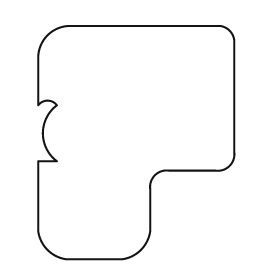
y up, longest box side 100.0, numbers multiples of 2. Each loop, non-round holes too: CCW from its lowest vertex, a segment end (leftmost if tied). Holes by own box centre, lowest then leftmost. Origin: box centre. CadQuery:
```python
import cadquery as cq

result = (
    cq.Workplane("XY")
    .moveTo(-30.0, -50.0)
    .lineTo(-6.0, -50.0)
    .threePointArc((2.0, -46.0), (6.0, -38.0))
    .lineTo(6.0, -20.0)
    .threePointArc((8.0, -14.0), (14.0, -12.0))
    .lineTo(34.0, -12.0)
    .threePointArc((40.0, -10.0), (42.0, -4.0))
    .lineTo(42.0, 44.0)
    .threePointArc((40.0, 48.0), (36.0, 50.0))
    .lineTo(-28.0, 50.0)
    .threePointArc((-38.0, 46.0), (-42.0, 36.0))
    .lineTo(-42.0, 16.0)
    .threePointArc((-38.0, 18.0), (-34.0, 16.0))
    .threePointArc((-40.0, 4.0), (-34.0, -8.0))
    .lineTo(-42.0, -8.0)
    .lineTo(-42.0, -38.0)
    .threePointArc((-38.0, -46.0), (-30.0, -50.0))
    .close()
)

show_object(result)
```